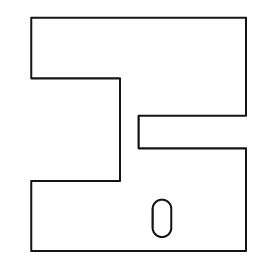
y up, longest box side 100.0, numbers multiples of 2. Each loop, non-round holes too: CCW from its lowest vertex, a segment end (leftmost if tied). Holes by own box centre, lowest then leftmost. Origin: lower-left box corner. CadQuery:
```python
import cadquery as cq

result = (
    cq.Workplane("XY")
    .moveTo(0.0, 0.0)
    .lineTo(92.0, 0.0)
    .lineTo(92.0, 44.0)
    .lineTo(46.0, 44.0)
    .lineTo(46.0, 58.0)
    .lineTo(92.0, 58.0)
    .lineTo(92.0, 100.0)
    .lineTo(0.0, 100.0)
    .lineTo(0.0, 74.0)
    .lineTo(38.0, 74.0)
    .lineTo(38.0, 30.0)
    .lineTo(0.0, 30.0)
    .close()
    .moveTo(52.0, 10.0)
    .threePointArc((56.0, 6.0), (60.0, 10.0))
    .lineTo(60.0, 18.0)
    .threePointArc((56.0, 22.0), (52.0, 18.0))
    .close()
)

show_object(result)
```